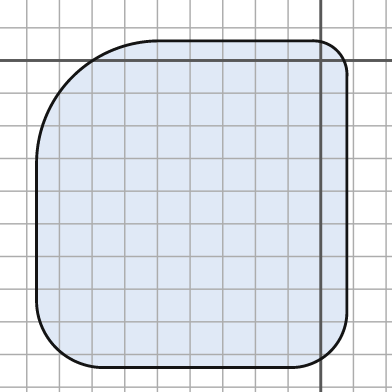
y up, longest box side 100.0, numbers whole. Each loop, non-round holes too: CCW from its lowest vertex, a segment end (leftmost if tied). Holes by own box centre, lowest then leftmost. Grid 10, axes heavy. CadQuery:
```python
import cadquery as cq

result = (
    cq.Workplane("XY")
    .moveTo(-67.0, -94.0)
    .lineTo(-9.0, -94.0)
    .threePointArc((3.0, -89.0), (8.0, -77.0))
    .lineTo(8.0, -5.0)
    .threePointArc((5.0, 3.0), (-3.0, 6.0))
    .lineTo(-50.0, 6.0)
    .threePointArc((-76.0, -5.0), (-87.0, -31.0))
    .lineTo(-87.0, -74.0)
    .threePointArc((-81.0, -88.0), (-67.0, -94.0))
    .close()
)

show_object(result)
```